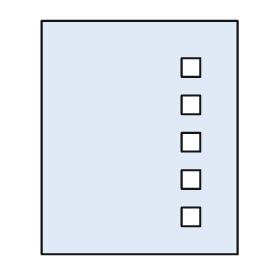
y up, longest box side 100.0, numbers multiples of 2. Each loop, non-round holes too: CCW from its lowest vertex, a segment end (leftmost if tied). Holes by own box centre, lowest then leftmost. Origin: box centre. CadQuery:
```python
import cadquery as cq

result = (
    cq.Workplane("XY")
    .moveTo(-42.0, -50.0)
    .lineTo(42.0, -50.0)
    .lineTo(42.0, 50.0)
    .lineTo(-42.0, 50.0)
    .close()
    .moveTo(18.0, -38.0)
    .lineTo(26.0, -38.0)
    .lineTo(26.0, -30.0)
    .lineTo(18.0, -30.0)
    .close()
    .moveTo(18.0, -22.0)
    .lineTo(26.0, -22.0)
    .lineTo(26.0, -14.0)
    .lineTo(18.0, -14.0)
    .close()
    .moveTo(18.0, -6.0)
    .lineTo(26.0, -6.0)
    .lineTo(26.0, 2.0)
    .lineTo(18.0, 2.0)
    .close()
    .moveTo(18.0, 10.0)
    .lineTo(26.0, 10.0)
    .lineTo(26.0, 18.0)
    .lineTo(18.0, 18.0)
    .close()
    .moveTo(18.0, 26.0)
    .lineTo(26.0, 26.0)
    .lineTo(26.0, 34.0)
    .lineTo(18.0, 34.0)
    .close()
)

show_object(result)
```